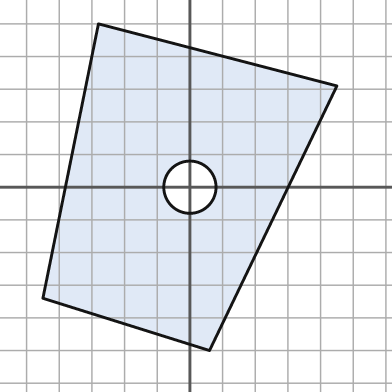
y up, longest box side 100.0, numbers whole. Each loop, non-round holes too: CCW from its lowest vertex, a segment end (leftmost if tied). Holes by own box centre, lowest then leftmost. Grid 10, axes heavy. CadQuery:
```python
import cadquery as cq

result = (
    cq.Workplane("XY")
    .moveTo(6.0, -50.0)
    .lineTo(45.0, 31.0)
    .lineTo(-28.0, 50.0)
    .lineTo(-45.0, -34.0)
    .close()
    .moveTo(0.0, 0.0)
    .circle(8.0)
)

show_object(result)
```